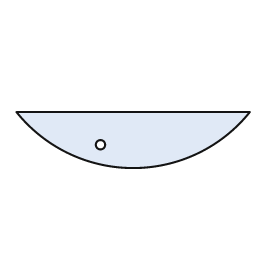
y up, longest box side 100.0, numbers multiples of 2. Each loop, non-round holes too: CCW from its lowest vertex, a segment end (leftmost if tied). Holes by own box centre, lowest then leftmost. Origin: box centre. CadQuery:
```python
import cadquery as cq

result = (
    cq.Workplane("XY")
    .moveTo(-50.0, 12.0)
    .threePointArc((0.0, -12.0), (50.0, 12.0))
    .close()
    .moveTo(-14.0, -2.0)
    .circle(2.0)
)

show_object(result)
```